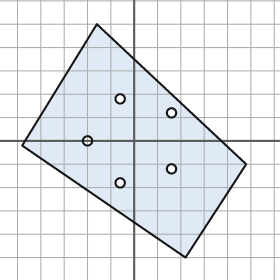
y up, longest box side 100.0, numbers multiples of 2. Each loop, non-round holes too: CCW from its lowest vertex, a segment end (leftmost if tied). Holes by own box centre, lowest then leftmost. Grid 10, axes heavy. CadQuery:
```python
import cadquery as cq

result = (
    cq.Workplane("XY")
    .moveTo(22.0, -50.0)
    .lineTo(48.0, -10.0)
    .lineTo(-16.0, 50.0)
    .lineTo(-48.0, -2.0)
    .close()
    .moveTo(-6.0, -18.0)
    .circle(2.0)
    .moveTo(16.0, -12.0)
    .circle(2.0)
    .moveTo(-20.0, 0.0)
    .circle(2.0)
    .moveTo(16.0, 12.0)
    .circle(2.0)
    .moveTo(-6.0, 18.0)
    .circle(2.0)
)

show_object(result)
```